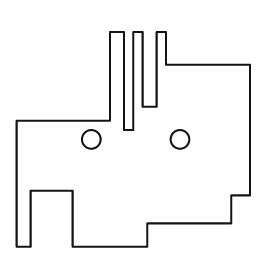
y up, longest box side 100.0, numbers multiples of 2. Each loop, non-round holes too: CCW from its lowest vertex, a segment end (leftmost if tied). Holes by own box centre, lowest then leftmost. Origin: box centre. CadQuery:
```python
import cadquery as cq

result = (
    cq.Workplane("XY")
    .moveTo(-50.0, -46.0)
    .lineTo(-44.0, -46.0)
    .lineTo(-44.0, -22.0)
    .lineTo(-26.0, -22.0)
    .lineTo(-26.0, -46.0)
    .lineTo(6.0, -46.0)
    .lineTo(6.0, -36.0)
    .lineTo(42.0, -36.0)
    .lineTo(42.0, -24.0)
    .lineTo(50.0, -24.0)
    .lineTo(50.0, 32.0)
    .lineTo(14.0, 32.0)
    .lineTo(14.0, 46.0)
    .lineTo(10.0, 46.0)
    .lineTo(10.0, 14.0)
    .lineTo(4.0, 14.0)
    .lineTo(4.0, 46.0)
    .lineTo(0.0, 46.0)
    .lineTo(0.0, 4.0)
    .lineTo(-4.0, 4.0)
    .lineTo(-4.0, 46.0)
    .lineTo(-10.0, 46.0)
    .lineTo(-10.0, 8.0)
    .lineTo(-50.0, 8.0)
    .close()
    .moveTo(-18.0, 0.0)
    .circle(4.0)
    .moveTo(20.0, 0.0)
    .circle(4.0)
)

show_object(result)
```